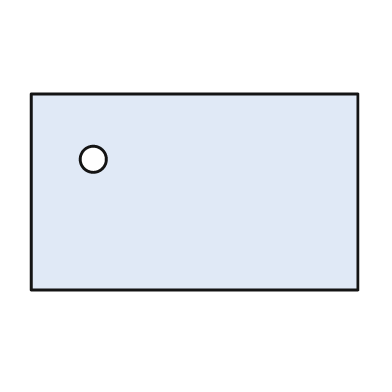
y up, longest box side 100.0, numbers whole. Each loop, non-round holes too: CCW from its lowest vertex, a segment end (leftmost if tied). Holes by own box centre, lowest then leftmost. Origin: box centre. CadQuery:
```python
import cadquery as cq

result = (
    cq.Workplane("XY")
    .moveTo(-50.0, -30.0)
    .lineTo(50.0, -30.0)
    .lineTo(50.0, 30.0)
    .lineTo(-50.0, 30.0)
    .close()
    .moveTo(-31.0, 10.0)
    .circle(4.0)
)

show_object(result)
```